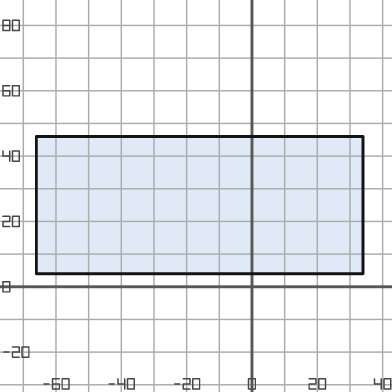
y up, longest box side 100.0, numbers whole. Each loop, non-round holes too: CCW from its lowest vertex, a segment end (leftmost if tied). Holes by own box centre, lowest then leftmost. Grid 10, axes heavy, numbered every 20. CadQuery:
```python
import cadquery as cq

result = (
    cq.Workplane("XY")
    .moveTo(-66.0, 4.0)
    .lineTo(34.0, 4.0)
    .lineTo(34.0, 46.0)
    .lineTo(-66.0, 46.0)
    .close()
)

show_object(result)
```